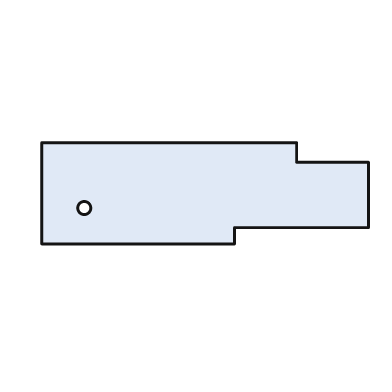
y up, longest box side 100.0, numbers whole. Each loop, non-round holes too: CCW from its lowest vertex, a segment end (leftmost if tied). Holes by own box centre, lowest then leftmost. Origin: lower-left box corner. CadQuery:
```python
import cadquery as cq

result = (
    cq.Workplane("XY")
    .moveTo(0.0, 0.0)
    .lineTo(59.0, 0.0)
    .lineTo(59.0, 5.0)
    .lineTo(100.0, 5.0)
    .lineTo(100.0, 25.0)
    .lineTo(78.0, 25.0)
    .lineTo(78.0, 31.0)
    .lineTo(0.0, 31.0)
    .close()
    .moveTo(13.0, 11.0)
    .circle(2.0)
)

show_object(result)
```